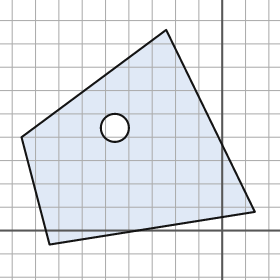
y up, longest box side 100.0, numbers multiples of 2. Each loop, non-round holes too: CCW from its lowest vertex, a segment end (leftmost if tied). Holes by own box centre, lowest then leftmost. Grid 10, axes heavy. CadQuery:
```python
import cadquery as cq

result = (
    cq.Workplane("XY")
    .moveTo(-74.0, -6.0)
    .lineTo(14.0, 8.0)
    .lineTo(-24.0, 86.0)
    .lineTo(-86.0, 40.0)
    .close()
    .moveTo(-46.0, 44.0)
    .circle(6.0)
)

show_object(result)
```